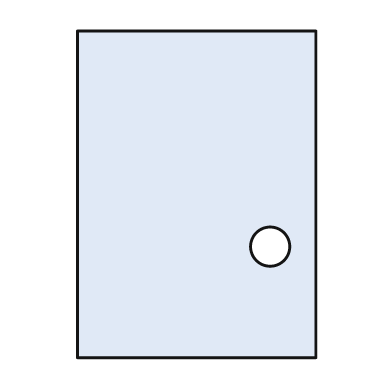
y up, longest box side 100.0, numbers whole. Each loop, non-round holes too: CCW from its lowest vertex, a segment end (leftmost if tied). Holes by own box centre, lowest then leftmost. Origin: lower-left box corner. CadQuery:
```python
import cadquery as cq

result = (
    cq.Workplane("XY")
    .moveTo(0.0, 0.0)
    .lineTo(73.0, 0.0)
    .lineTo(73.0, 100.0)
    .lineTo(0.0, 100.0)
    .close()
    .moveTo(59.0, 34.0)
    .circle(6.0)
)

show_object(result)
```